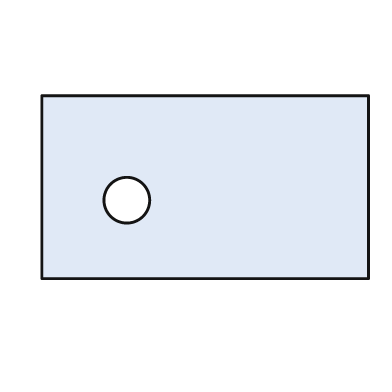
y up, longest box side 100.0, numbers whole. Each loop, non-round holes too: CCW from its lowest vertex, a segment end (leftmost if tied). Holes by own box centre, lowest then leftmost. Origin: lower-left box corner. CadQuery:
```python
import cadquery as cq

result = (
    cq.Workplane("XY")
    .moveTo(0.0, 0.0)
    .lineTo(100.0, 0.0)
    .lineTo(100.0, 56.0)
    .lineTo(0.0, 56.0)
    .close()
    .moveTo(26.0, 24.0)
    .circle(7.0)
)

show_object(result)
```